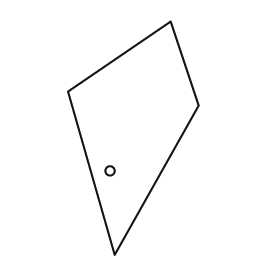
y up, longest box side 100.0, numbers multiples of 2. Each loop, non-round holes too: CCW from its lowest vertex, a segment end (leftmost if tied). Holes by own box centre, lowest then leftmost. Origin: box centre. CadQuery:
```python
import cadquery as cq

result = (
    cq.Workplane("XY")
    .moveTo(-8.0, -50.0)
    .lineTo(28.0, 14.0)
    .lineTo(16.0, 50.0)
    .lineTo(-28.0, 20.0)
    .close()
    .moveTo(-10.0, -14.0)
    .circle(2.0)
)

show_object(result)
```